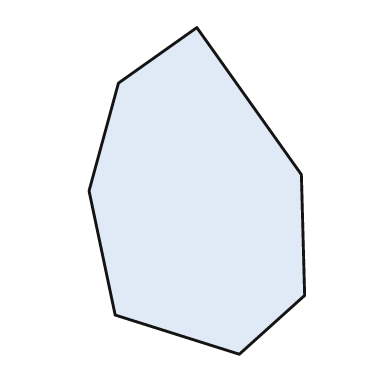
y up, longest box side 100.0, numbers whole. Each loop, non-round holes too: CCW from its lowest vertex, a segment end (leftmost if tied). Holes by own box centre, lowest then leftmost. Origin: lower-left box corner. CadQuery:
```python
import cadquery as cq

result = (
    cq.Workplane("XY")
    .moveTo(46.0, 0.0)
    .lineTo(66.0, 18.0)
    .lineTo(65.0, 55.0)
    .lineTo(33.0, 100.0)
    .lineTo(9.0, 83.0)
    .lineTo(0.0, 50.0)
    .lineTo(8.0, 12.0)
    .close()
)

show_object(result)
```